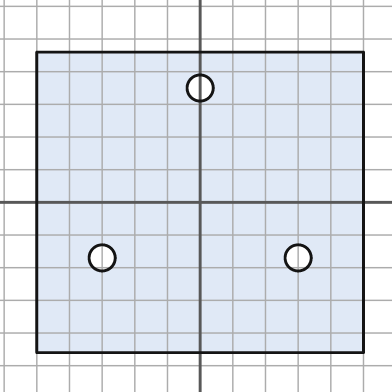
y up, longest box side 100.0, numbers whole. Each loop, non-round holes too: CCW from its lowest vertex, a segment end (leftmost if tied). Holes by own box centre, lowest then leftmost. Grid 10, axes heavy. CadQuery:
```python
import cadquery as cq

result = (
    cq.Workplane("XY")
    .moveTo(-50.0, -46.0)
    .lineTo(50.0, -46.0)
    .lineTo(50.0, 46.0)
    .lineTo(-50.0, 46.0)
    .close()
    .moveTo(-30.0, -17.0)
    .circle(4.0)
    .moveTo(30.0, -17.0)
    .circle(4.0)
    .moveTo(0.0, 35.0)
    .circle(4.0)
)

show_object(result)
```